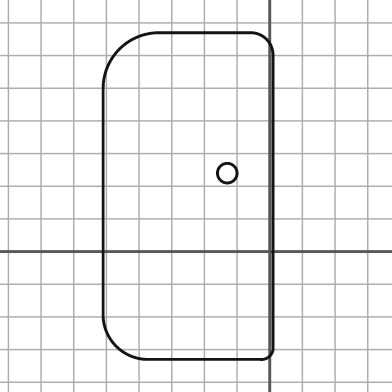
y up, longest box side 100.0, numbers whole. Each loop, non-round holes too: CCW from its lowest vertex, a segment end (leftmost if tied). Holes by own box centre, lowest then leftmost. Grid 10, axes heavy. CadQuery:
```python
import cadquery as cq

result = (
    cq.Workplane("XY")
    .moveTo(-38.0, -33.0)
    .lineTo(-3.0, -33.0)
    .threePointArc((0.0, -32.0), (1.0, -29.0))
    .lineTo(1.0, 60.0)
    .threePointArc((-1.0, 65.0), (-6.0, 67.0))
    .lineTo(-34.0, 67.0)
    .threePointArc((-46.0, 62.0), (-51.0, 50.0))
    .lineTo(-51.0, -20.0)
    .threePointArc((-47.0, -29.0), (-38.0, -33.0))
    .close()
    .moveTo(-13.0, 24.0)
    .circle(3.0)
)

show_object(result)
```